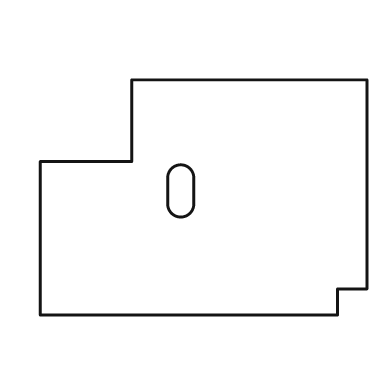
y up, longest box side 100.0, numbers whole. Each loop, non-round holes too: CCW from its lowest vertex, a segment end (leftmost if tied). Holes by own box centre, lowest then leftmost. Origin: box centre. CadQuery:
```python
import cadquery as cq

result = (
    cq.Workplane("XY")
    .moveTo(-50.0, -36.0)
    .lineTo(41.0, -36.0)
    .lineTo(41.0, -28.0)
    .lineTo(50.0, -28.0)
    .lineTo(50.0, 36.0)
    .lineTo(-22.0, 36.0)
    .lineTo(-22.0, 11.0)
    .lineTo(-50.0, 11.0)
    .close()
    .moveTo(-11.0, -2.0)
    .threePointArc((-7.0, -6.0), (-3.0, -2.0))
    .lineTo(-3.0, 6.0)
    .threePointArc((-7.0, 10.0), (-11.0, 6.0))
    .close()
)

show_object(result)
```